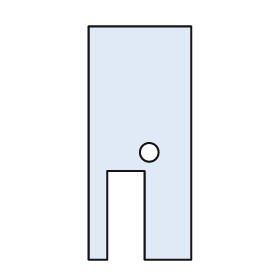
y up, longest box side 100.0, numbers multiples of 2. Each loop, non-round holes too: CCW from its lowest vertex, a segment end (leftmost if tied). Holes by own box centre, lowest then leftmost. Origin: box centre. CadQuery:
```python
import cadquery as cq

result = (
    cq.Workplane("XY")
    .moveTo(-22.0, -50.0)
    .lineTo(-14.0, -50.0)
    .lineTo(-14.0, -12.0)
    .lineTo(2.0, -12.0)
    .lineTo(2.0, -50.0)
    .lineTo(22.0, -50.0)
    .lineTo(22.0, 50.0)
    .lineTo(-22.0, 50.0)
    .close()
    .moveTo(4.0, -4.0)
    .circle(4.0)
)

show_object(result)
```